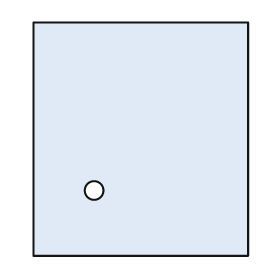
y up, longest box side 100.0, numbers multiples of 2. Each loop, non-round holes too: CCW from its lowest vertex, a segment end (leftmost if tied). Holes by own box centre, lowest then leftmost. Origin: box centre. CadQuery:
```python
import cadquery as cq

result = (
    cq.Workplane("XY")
    .moveTo(-46.0, -50.0)
    .lineTo(46.0, -50.0)
    .lineTo(46.0, 50.0)
    .lineTo(-46.0, 50.0)
    .close()
    .moveTo(-20.0, -22.0)
    .circle(4.0)
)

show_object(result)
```